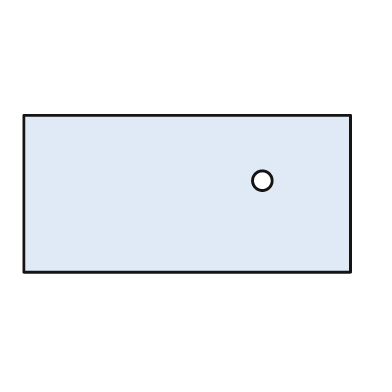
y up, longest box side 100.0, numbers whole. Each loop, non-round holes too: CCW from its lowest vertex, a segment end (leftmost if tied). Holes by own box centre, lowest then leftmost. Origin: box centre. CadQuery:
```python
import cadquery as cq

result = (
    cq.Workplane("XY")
    .moveTo(-50.0, -24.0)
    .lineTo(50.0, -24.0)
    .lineTo(50.0, 24.0)
    .lineTo(-50.0, 24.0)
    .close()
    .moveTo(23.0, 4.0)
    .circle(3.0)
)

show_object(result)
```